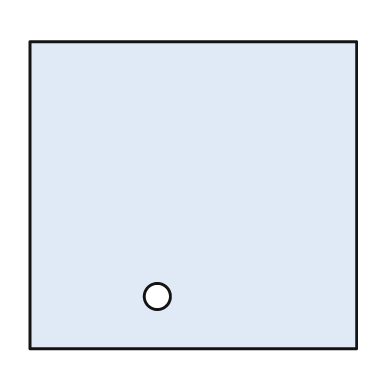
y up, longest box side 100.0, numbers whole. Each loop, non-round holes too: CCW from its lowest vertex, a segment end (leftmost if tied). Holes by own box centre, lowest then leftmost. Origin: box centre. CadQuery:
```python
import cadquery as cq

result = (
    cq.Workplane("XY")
    .moveTo(-50.0, -47.0)
    .lineTo(50.0, -47.0)
    .lineTo(50.0, 47.0)
    .lineTo(-50.0, 47.0)
    .close()
    .moveTo(-11.0, -31.0)
    .circle(4.0)
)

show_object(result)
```